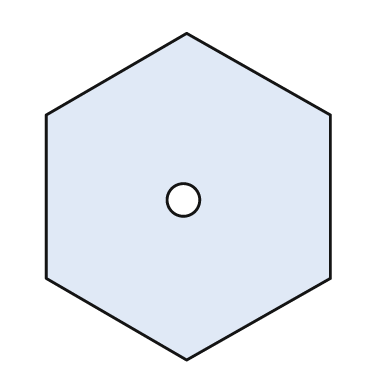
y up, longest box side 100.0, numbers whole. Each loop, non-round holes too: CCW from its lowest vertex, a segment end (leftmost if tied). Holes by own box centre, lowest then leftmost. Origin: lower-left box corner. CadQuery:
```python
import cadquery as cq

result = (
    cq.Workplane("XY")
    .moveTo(43.0, 0.0)
    .lineTo(87.0, 25.0)
    .lineTo(87.0, 75.0)
    .lineTo(43.0, 100.0)
    .lineTo(0.0, 75.0)
    .lineTo(0.0, 25.0)
    .close()
    .moveTo(42.0, 49.0)
    .circle(5.0)
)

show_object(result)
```